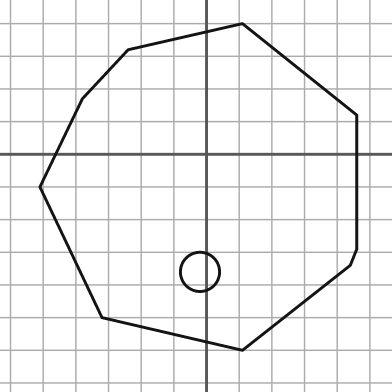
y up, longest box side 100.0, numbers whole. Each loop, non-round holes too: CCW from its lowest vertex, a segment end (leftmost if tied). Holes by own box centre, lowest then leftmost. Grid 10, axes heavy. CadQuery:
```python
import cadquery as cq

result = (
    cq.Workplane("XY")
    .moveTo(11.0, -60.0)
    .lineTo(44.0, -34.0)
    .lineTo(46.0, -29.0)
    .lineTo(46.0, 12.0)
    .lineTo(11.0, 40.0)
    .lineTo(-24.0, 32.0)
    .lineTo(-38.0, 17.0)
    .lineTo(-51.0, -10.0)
    .lineTo(-32.0, -50.0)
    .close()
    .moveTo(-2.0, -36.0)
    .circle(6.0)
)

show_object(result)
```